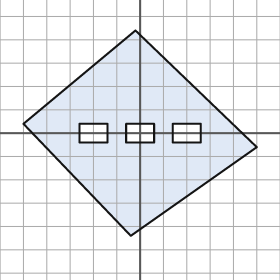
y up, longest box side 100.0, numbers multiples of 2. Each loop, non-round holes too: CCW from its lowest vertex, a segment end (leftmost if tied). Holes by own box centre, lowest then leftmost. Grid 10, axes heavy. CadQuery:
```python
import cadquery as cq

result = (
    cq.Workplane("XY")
    .moveTo(-4.0, -44.0)
    .lineTo(50.0, -6.0)
    .lineTo(-2.0, 44.0)
    .lineTo(-50.0, 4.0)
    .close()
    .moveTo(-26.0, -4.0)
    .lineTo(-14.0, -4.0)
    .lineTo(-14.0, 4.0)
    .lineTo(-26.0, 4.0)
    .close()
    .moveTo(-6.0, -4.0)
    .lineTo(6.0, -4.0)
    .lineTo(6.0, 4.0)
    .lineTo(-6.0, 4.0)
    .close()
    .moveTo(14.0, -4.0)
    .lineTo(26.0, -4.0)
    .lineTo(26.0, 4.0)
    .lineTo(14.0, 4.0)
    .close()
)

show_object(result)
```